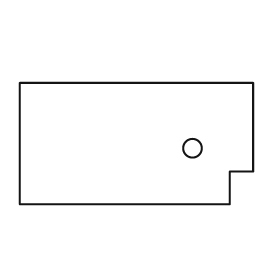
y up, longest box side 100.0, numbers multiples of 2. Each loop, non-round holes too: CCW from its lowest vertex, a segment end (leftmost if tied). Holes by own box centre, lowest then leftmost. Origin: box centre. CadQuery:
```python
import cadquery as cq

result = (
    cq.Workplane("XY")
    .moveTo(-50.0, -26.0)
    .lineTo(40.0, -26.0)
    .lineTo(40.0, -12.0)
    .lineTo(50.0, -12.0)
    .lineTo(50.0, 26.0)
    .lineTo(-50.0, 26.0)
    .close()
    .moveTo(24.0, -2.0)
    .circle(4.0)
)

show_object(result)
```